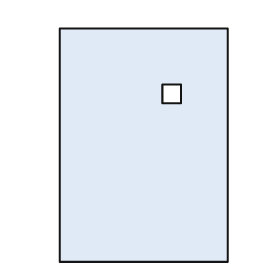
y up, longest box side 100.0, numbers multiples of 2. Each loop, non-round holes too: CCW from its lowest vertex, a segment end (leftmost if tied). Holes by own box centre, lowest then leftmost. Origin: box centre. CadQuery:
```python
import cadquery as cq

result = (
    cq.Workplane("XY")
    .moveTo(-36.0, -50.0)
    .lineTo(36.0, -50.0)
    .lineTo(36.0, 50.0)
    .lineTo(-36.0, 50.0)
    .close()
    .moveTo(8.0, 18.0)
    .lineTo(16.0, 18.0)
    .lineTo(16.0, 26.0)
    .lineTo(8.0, 26.0)
    .close()
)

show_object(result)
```